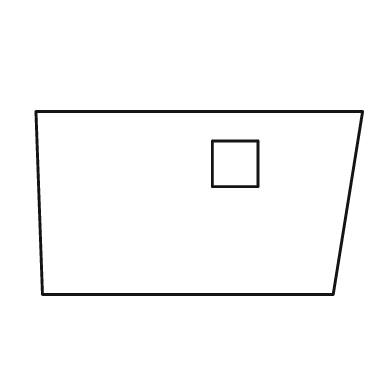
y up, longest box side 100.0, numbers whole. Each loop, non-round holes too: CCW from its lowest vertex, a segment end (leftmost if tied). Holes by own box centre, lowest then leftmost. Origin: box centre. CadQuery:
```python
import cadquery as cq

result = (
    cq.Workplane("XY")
    .moveTo(-48.0, -28.0)
    .lineTo(41.0, -28.0)
    .lineTo(50.0, 28.0)
    .lineTo(-50.0, 28.0)
    .close()
    .moveTo(4.0, 5.0)
    .lineTo(18.0, 5.0)
    .lineTo(18.0, 19.0)
    .lineTo(4.0, 19.0)
    .close()
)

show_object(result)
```